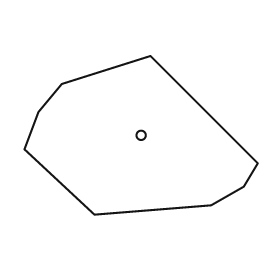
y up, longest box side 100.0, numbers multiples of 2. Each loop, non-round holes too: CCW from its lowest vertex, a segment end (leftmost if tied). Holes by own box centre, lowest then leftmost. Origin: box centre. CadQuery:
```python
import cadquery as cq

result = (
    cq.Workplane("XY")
    .moveTo(-20.0, -34.0)
    .lineTo(30.0, -30.0)
    .lineTo(44.0, -22.0)
    .lineTo(50.0, -12.0)
    .lineTo(4.0, 34.0)
    .lineTo(-34.0, 22.0)
    .lineTo(-44.0, 10.0)
    .lineTo(-50.0, -6.0)
    .close()
    .moveTo(0.0, 0.0)
    .circle(2.0)
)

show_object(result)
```